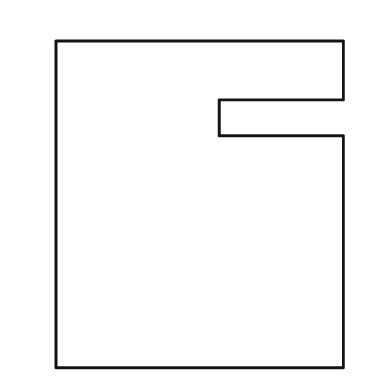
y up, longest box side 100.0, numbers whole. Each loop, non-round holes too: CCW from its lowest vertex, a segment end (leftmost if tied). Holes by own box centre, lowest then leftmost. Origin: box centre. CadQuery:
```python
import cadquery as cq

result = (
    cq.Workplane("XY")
    .moveTo(-44.0, -50.0)
    .lineTo(44.0, -50.0)
    .lineTo(44.0, 21.0)
    .lineTo(6.0, 21.0)
    .lineTo(6.0, 32.0)
    .lineTo(44.0, 32.0)
    .lineTo(44.0, 50.0)
    .lineTo(-44.0, 50.0)
    .close()
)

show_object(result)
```